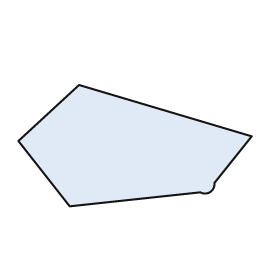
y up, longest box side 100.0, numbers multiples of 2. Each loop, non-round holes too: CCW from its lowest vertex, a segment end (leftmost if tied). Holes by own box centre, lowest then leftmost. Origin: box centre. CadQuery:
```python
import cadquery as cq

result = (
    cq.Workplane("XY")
    .moveTo(-28.0, -26.0)
    .lineTo(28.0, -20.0)
    .threePointArc((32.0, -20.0), (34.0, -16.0))
    .lineTo(50.0, 4.0)
    .lineTo(-24.0, 26.0)
    .lineTo(-50.0, 2.0)
    .close()
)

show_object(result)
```